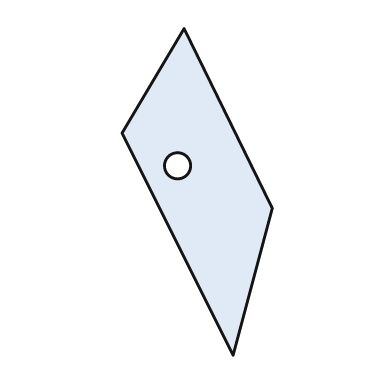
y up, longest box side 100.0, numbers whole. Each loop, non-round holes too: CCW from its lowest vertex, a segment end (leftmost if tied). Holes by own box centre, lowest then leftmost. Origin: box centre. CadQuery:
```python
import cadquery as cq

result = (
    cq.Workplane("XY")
    .moveTo(11.0, -50.0)
    .lineTo(23.0, -5.0)
    .lineTo(-4.0, 50.0)
    .lineTo(-23.0, 18.0)
    .close()
    .moveTo(-6.0, 8.0)
    .circle(4.0)
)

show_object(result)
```